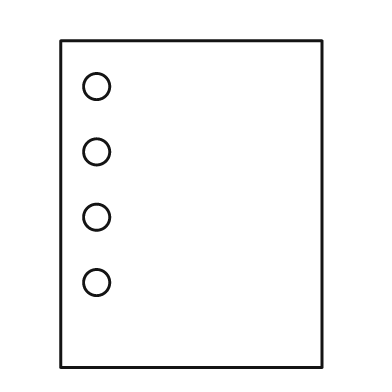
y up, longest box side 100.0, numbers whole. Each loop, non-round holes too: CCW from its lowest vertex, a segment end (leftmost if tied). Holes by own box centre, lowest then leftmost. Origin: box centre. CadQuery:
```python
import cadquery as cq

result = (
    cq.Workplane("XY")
    .moveTo(-40.0, -50.0)
    .lineTo(40.0, -50.0)
    .lineTo(40.0, 50.0)
    .lineTo(-40.0, 50.0)
    .close()
    .moveTo(-29.0, -24.0)
    .circle(4.0)
    .moveTo(-29.0, -4.0)
    .circle(4.0)
    .moveTo(-29.0, 16.0)
    .circle(4.0)
    .moveTo(-29.0, 36.0)
    .circle(4.0)
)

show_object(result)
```